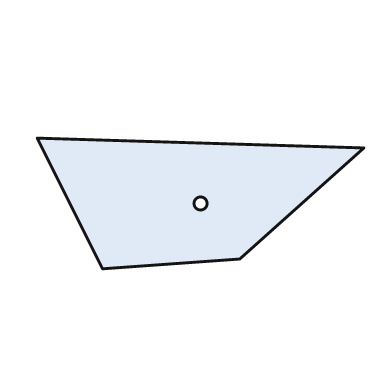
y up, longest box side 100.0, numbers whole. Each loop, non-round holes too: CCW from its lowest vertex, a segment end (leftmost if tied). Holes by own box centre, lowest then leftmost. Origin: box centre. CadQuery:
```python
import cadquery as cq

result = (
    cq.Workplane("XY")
    .moveTo(-30.0, -20.0)
    .lineTo(12.0, -17.0)
    .lineTo(50.0, 17.0)
    .lineTo(-50.0, 20.0)
    .close()
    .moveTo(0.0, 0.0)
    .circle(2.0)
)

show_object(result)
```